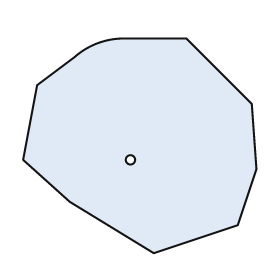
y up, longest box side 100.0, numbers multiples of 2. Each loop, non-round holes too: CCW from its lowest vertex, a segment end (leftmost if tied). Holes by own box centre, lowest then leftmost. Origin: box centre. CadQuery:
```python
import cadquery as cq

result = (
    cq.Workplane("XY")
    .moveTo(6.0, -46.0)
    .lineTo(42.0, -34.0)
    .lineTo(50.0, -10.0)
    .lineTo(48.0, 18.0)
    .lineTo(20.0, 46.0)
    .lineTo(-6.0, 46.0)
    .threePointArc((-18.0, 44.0), (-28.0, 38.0))
    .lineTo(-44.0, 26.0)
    .lineTo(-50.0, -6.0)
    .lineTo(-30.0, -24.0)
    .close()
    .moveTo(-4.0, -6.0)
    .circle(2.0)
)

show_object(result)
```